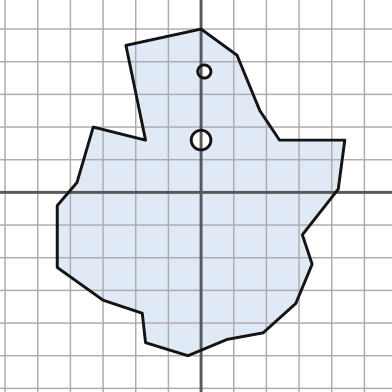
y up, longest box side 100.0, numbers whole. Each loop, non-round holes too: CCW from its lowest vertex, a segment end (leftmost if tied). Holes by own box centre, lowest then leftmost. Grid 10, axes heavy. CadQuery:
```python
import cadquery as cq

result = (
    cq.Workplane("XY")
    .moveTo(-4.0, -50.0)
    .lineTo(8.0, -45.0)
    .lineTo(19.0, -43.0)
    .lineTo(29.0, -34.0)
    .lineTo(34.0, -22.0)
    .lineTo(31.0, -13.0)
    .lineTo(42.0, 1.0)
    .lineTo(44.0, 16.0)
    .lineTo(24.0, 16.0)
    .lineTo(18.0, 25.0)
    .lineTo(11.0, 42.0)
    .lineTo(0.0, 50.0)
    .lineTo(-23.0, 45.0)
    .lineTo(-17.0, 16.0)
    .lineTo(-33.0, 20.0)
    .lineTo(-38.0, 3.0)
    .lineTo(-44.0, -4.0)
    .lineTo(-44.0, -23.0)
    .lineTo(-30.0, -33.0)
    .lineTo(-18.0, -37.0)
    .lineTo(-17.0, -46.0)
    .close()
    .moveTo(0.0, 16.0)
    .circle(3.0)
    .moveTo(1.0, 37.0)
    .circle(2.0)
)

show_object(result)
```